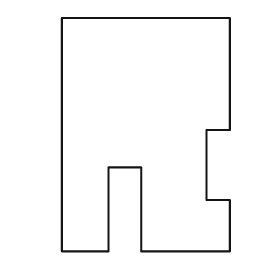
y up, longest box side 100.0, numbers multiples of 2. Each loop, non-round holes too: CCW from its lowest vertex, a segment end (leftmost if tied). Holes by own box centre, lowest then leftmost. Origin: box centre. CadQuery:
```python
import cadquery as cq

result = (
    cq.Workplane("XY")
    .moveTo(-36.0, -50.0)
    .lineTo(-16.0, -50.0)
    .lineTo(-16.0, -14.0)
    .lineTo(-2.0, -14.0)
    .lineTo(-2.0, -50.0)
    .lineTo(36.0, -50.0)
    .lineTo(36.0, -28.0)
    .lineTo(26.0, -28.0)
    .lineTo(26.0, 2.0)
    .lineTo(36.0, 2.0)
    .lineTo(36.0, 50.0)
    .lineTo(-36.0, 50.0)
    .close()
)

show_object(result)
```